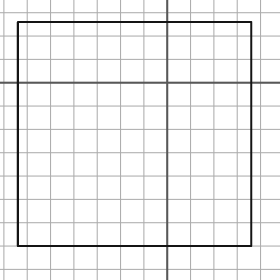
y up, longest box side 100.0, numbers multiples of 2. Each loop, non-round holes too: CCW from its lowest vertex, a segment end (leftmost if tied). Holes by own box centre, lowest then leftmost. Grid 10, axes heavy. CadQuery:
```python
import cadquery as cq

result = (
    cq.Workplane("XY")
    .moveTo(-64.0, -70.0)
    .lineTo(36.0, -70.0)
    .lineTo(36.0, 26.0)
    .lineTo(-64.0, 26.0)
    .close()
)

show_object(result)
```